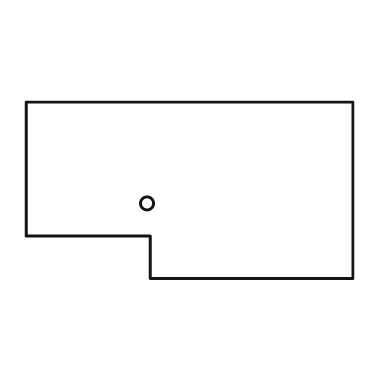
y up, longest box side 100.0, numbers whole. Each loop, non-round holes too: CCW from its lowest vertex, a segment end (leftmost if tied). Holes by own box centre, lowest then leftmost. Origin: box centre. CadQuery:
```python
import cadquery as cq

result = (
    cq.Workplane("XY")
    .moveTo(-12.0, -27.0)
    .lineTo(50.0, -27.0)
    .lineTo(50.0, 27.0)
    .lineTo(-50.0, 27.0)
    .lineTo(-50.0, -14.0)
    .lineTo(-12.0, -14.0)
    .close()
    .moveTo(-13.0, -4.0)
    .circle(2.0)
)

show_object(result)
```